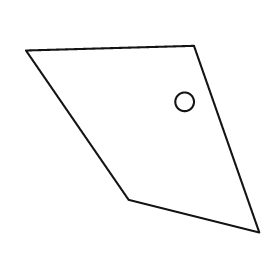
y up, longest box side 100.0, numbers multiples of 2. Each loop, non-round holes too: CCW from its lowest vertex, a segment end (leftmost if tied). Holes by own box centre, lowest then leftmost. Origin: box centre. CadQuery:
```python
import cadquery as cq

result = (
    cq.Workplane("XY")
    .moveTo(50.0, -40.0)
    .lineTo(22.0, 40.0)
    .lineTo(-50.0, 38.0)
    .lineTo(-6.0, -26.0)
    .close()
    .moveTo(18.0, 16.0)
    .circle(4.0)
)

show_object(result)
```